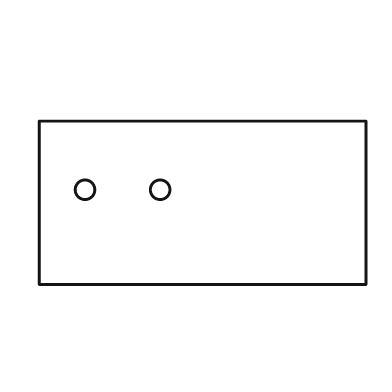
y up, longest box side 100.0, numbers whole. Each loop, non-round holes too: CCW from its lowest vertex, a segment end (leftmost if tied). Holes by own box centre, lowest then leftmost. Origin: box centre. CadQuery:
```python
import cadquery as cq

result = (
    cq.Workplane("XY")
    .moveTo(-50.0, -25.0)
    .lineTo(50.0, -25.0)
    .lineTo(50.0, 25.0)
    .lineTo(-50.0, 25.0)
    .close()
    .moveTo(-36.0, 4.0)
    .circle(3.0)
    .moveTo(-13.0, 4.0)
    .circle(3.0)
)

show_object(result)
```